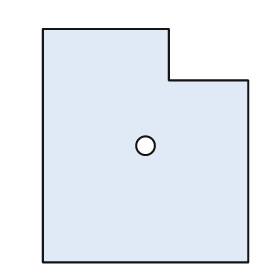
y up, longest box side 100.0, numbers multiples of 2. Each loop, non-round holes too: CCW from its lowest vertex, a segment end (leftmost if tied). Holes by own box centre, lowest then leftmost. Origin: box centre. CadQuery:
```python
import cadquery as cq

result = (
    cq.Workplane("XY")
    .moveTo(-44.0, -50.0)
    .lineTo(44.0, -50.0)
    .lineTo(44.0, 28.0)
    .lineTo(10.0, 28.0)
    .lineTo(10.0, 50.0)
    .lineTo(-44.0, 50.0)
    .close()
    .moveTo(0.0, 0.0)
    .circle(4.0)
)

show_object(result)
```